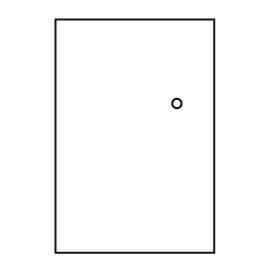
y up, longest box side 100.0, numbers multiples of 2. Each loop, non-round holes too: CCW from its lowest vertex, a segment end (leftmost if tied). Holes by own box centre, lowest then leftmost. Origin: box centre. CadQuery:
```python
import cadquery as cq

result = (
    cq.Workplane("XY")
    .moveTo(-34.0, -50.0)
    .lineTo(34.0, -50.0)
    .lineTo(34.0, 50.0)
    .lineTo(-34.0, 50.0)
    .close()
    .moveTo(18.0, 14.0)
    .circle(2.0)
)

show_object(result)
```